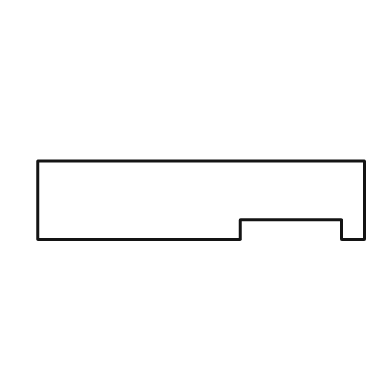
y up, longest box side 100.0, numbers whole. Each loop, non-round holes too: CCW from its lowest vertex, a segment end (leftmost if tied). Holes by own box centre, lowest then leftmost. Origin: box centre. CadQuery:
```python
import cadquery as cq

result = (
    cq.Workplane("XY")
    .moveTo(-50.0, -12.0)
    .lineTo(12.0, -12.0)
    .lineTo(12.0, -6.0)
    .lineTo(43.0, -6.0)
    .lineTo(43.0, -12.0)
    .lineTo(50.0, -12.0)
    .lineTo(50.0, 12.0)
    .lineTo(-50.0, 12.0)
    .close()
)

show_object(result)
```